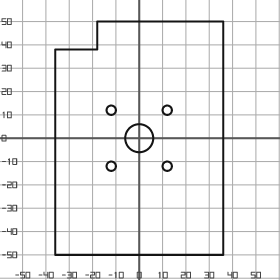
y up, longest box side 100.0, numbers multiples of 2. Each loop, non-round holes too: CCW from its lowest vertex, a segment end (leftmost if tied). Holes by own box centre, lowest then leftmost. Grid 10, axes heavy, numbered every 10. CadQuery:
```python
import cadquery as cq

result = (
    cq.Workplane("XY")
    .moveTo(-36.0, -50.0)
    .lineTo(36.0, -50.0)
    .lineTo(36.0, 50.0)
    .lineTo(-18.0, 50.0)
    .lineTo(-18.0, 38.0)
    .lineTo(-36.0, 38.0)
    .close()
    .moveTo(-12.0, -12.0)
    .circle(2.0)
    .moveTo(12.0, -12.0)
    .circle(2.0)
    .moveTo(0.0, 0.0)
    .circle(6.0)
    .moveTo(-12.0, 12.0)
    .circle(2.0)
    .moveTo(12.0, 12.0)
    .circle(2.0)
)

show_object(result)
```